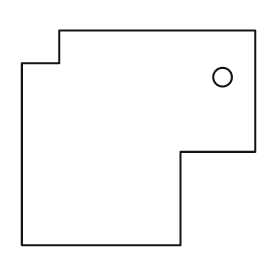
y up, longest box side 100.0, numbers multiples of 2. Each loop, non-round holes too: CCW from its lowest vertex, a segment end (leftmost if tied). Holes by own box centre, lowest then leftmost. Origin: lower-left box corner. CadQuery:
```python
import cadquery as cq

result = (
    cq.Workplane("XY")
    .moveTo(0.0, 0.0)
    .lineTo(68.0, 0.0)
    .lineTo(68.0, 40.0)
    .lineTo(100.0, 40.0)
    .lineTo(100.0, 92.0)
    .lineTo(16.0, 92.0)
    .lineTo(16.0, 78.0)
    .lineTo(0.0, 78.0)
    .close()
    .moveTo(86.0, 72.0)
    .circle(4.0)
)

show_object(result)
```